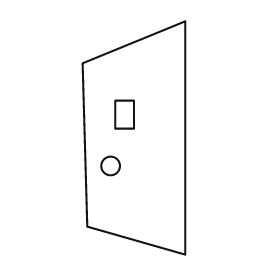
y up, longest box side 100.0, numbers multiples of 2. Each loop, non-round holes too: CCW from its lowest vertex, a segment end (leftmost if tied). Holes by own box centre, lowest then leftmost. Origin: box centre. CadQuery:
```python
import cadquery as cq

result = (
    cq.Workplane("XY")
    .moveTo(22.0, -50.0)
    .lineTo(22.0, 50.0)
    .lineTo(-22.0, 32.0)
    .lineTo(-20.0, -38.0)
    .close()
    .moveTo(-10.0, -12.0)
    .circle(4.0)
    .moveTo(-8.0, 4.0)
    .lineTo(0.0, 4.0)
    .lineTo(0.0, 16.0)
    .lineTo(-8.0, 16.0)
    .close()
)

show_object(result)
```